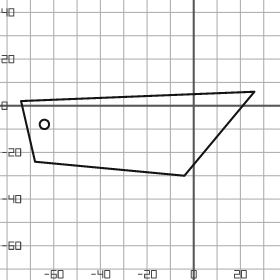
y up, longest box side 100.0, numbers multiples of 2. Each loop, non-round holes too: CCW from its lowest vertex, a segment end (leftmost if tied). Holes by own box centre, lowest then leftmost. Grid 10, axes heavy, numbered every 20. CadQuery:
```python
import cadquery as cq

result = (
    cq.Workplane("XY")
    .moveTo(-4.0, -30.0)
    .lineTo(26.0, 6.0)
    .lineTo(-74.0, 2.0)
    .lineTo(-68.0, -24.0)
    .close()
    .moveTo(-64.0, -8.0)
    .circle(2.0)
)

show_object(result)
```